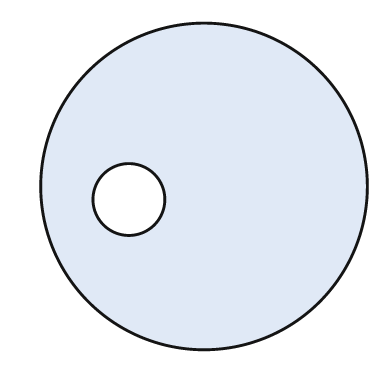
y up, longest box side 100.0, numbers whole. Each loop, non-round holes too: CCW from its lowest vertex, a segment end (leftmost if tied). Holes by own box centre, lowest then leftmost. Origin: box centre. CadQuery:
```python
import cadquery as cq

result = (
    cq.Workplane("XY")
    .moveTo(0.0, 0.0)
    .circle(50.0)
    .moveTo(-23.0, -4.0)
    .circle(11.0)
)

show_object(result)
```